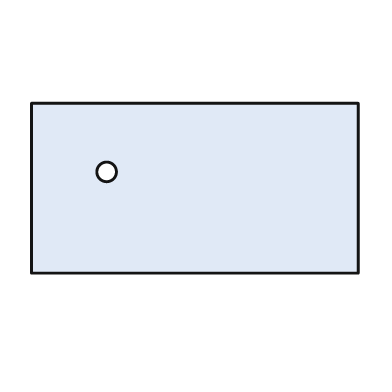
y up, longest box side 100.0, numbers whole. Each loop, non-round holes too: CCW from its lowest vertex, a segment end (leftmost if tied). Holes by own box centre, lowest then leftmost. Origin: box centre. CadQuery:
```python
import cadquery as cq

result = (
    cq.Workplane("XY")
    .moveTo(-50.0, -26.0)
    .lineTo(50.0, -26.0)
    .lineTo(50.0, 26.0)
    .lineTo(-50.0, 26.0)
    .close()
    .moveTo(-27.0, 5.0)
    .circle(3.0)
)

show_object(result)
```